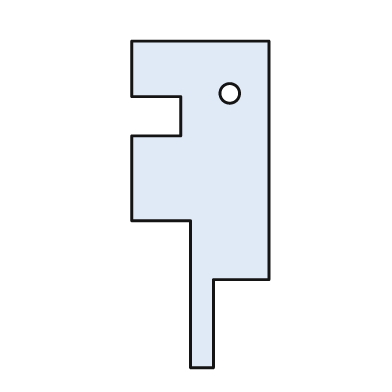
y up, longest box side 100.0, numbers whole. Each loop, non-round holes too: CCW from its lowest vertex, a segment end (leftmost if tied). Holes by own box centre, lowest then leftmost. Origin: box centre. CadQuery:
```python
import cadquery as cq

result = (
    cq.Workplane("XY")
    .moveTo(-3.0, -50.0)
    .lineTo(4.0, -50.0)
    .lineTo(4.0, -23.0)
    .lineTo(21.0, -23.0)
    .lineTo(21.0, 50.0)
    .lineTo(-21.0, 50.0)
    .lineTo(-21.0, 33.0)
    .lineTo(-6.0, 33.0)
    .lineTo(-6.0, 21.0)
    .lineTo(-21.0, 21.0)
    .lineTo(-21.0, -5.0)
    .lineTo(-3.0, -5.0)
    .close()
    .moveTo(9.0, 34.0)
    .circle(3.0)
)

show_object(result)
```